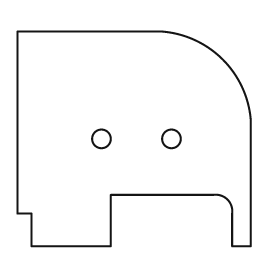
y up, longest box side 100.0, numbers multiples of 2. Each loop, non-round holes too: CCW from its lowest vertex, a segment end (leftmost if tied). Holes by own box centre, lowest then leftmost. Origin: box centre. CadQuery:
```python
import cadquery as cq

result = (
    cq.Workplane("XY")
    .moveTo(-44.0, -46.0)
    .lineTo(-10.0, -46.0)
    .lineTo(-10.0, -24.0)
    .lineTo(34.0, -24.0)
    .threePointArc((40.0, -26.0), (42.0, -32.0))
    .lineTo(42.0, -46.0)
    .lineTo(50.0, -46.0)
    .lineTo(50.0, 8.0)
    .threePointArc((38.0, 34.0), (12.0, 46.0))
    .lineTo(-50.0, 46.0)
    .lineTo(-50.0, -32.0)
    .lineTo(-44.0, -32.0)
    .close()
    .moveTo(-14.0, 0.0)
    .circle(4.0)
    .moveTo(16.0, 0.0)
    .circle(4.0)
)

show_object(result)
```